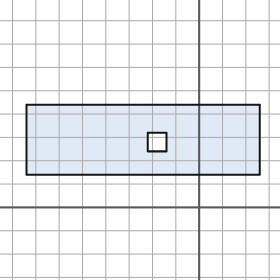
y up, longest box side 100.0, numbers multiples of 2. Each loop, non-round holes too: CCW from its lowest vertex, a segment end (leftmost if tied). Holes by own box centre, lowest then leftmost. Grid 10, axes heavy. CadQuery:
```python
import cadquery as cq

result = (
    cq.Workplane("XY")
    .moveTo(-74.0, 14.0)
    .lineTo(26.0, 14.0)
    .lineTo(26.0, 44.0)
    .lineTo(-74.0, 44.0)
    .close()
    .moveTo(-22.0, 24.0)
    .lineTo(-14.0, 24.0)
    .lineTo(-14.0, 32.0)
    .lineTo(-22.0, 32.0)
    .close()
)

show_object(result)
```